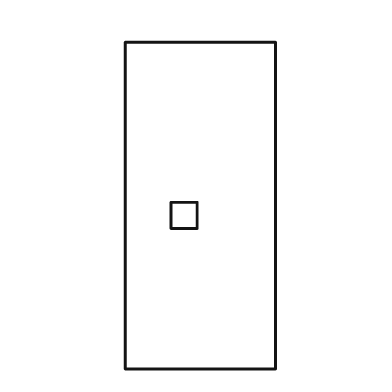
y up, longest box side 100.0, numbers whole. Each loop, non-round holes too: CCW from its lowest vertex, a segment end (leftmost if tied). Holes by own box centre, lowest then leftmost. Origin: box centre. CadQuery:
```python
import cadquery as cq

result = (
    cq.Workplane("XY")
    .moveTo(-23.0, -50.0)
    .lineTo(23.0, -50.0)
    .lineTo(23.0, 50.0)
    .lineTo(-23.0, 50.0)
    .close()
    .moveTo(-9.0, -7.0)
    .lineTo(-1.0, -7.0)
    .lineTo(-1.0, 1.0)
    .lineTo(-9.0, 1.0)
    .close()
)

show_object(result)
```